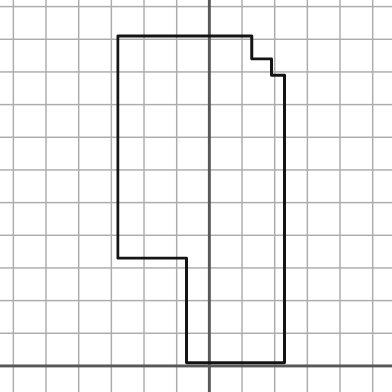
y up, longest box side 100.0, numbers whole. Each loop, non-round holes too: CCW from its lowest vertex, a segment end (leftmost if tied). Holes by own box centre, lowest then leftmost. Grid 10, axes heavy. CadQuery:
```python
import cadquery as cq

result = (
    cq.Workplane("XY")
    .moveTo(-7.0, 1.0)
    .lineTo(23.0, 1.0)
    .lineTo(23.0, 89.0)
    .lineTo(19.0, 89.0)
    .lineTo(19.0, 94.0)
    .lineTo(13.0, 94.0)
    .lineTo(13.0, 101.0)
    .lineTo(-28.0, 101.0)
    .lineTo(-28.0, 33.0)
    .lineTo(-7.0, 33.0)
    .close()
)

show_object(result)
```